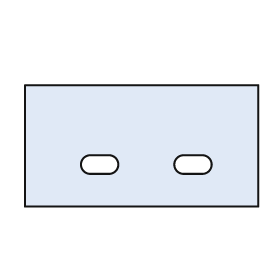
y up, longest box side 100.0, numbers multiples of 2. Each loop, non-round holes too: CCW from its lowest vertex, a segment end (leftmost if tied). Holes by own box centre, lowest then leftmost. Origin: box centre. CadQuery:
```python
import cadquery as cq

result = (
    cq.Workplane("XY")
    .moveTo(-50.0, -26.0)
    .lineTo(50.0, -26.0)
    .lineTo(50.0, 26.0)
    .lineTo(-50.0, 26.0)
    .close()
    .moveTo(-22.0, -12.0)
    .lineTo(-14.0, -12.0)
    .threePointArc((-10.0, -8.0), (-14.0, -4.0))
    .lineTo(-22.0, -4.0)
    .threePointArc((-26.0, -8.0), (-22.0, -12.0))
    .close()
    .moveTo(18.0, -12.0)
    .lineTo(26.0, -12.0)
    .threePointArc((30.0, -8.0), (26.0, -4.0))
    .lineTo(18.0, -4.0)
    .threePointArc((14.0, -8.0), (18.0, -12.0))
    .close()
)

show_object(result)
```